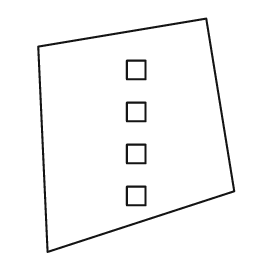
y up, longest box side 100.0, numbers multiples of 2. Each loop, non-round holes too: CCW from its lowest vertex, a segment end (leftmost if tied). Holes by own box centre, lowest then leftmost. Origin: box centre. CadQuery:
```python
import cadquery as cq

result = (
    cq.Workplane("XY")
    .moveTo(-38.0, -50.0)
    .lineTo(42.0, -24.0)
    .lineTo(30.0, 50.0)
    .lineTo(-42.0, 38.0)
    .close()
    .moveTo(-4.0, -30.0)
    .lineTo(4.0, -30.0)
    .lineTo(4.0, -22.0)
    .lineTo(-4.0, -22.0)
    .close()
    .moveTo(-4.0, -12.0)
    .lineTo(4.0, -12.0)
    .lineTo(4.0, -4.0)
    .lineTo(-4.0, -4.0)
    .close()
    .moveTo(-4.0, 6.0)
    .lineTo(4.0, 6.0)
    .lineTo(4.0, 14.0)
    .lineTo(-4.0, 14.0)
    .close()
    .moveTo(-4.0, 24.0)
    .lineTo(4.0, 24.0)
    .lineTo(4.0, 32.0)
    .lineTo(-4.0, 32.0)
    .close()
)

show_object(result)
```